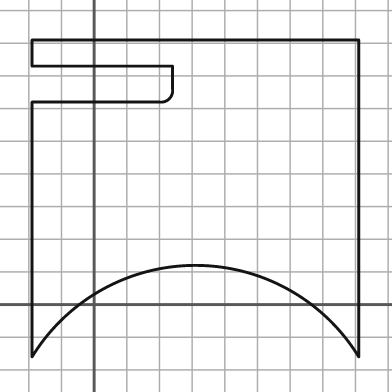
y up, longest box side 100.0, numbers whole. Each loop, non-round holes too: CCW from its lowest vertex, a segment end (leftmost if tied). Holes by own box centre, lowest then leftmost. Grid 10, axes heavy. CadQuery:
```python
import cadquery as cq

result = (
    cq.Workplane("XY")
    .moveTo(-19.0, -16.0)
    .threePointArc((31.0, 12.0), (81.0, -16.0))
    .lineTo(81.0, 81.0)
    .lineTo(-19.0, 81.0)
    .lineTo(-19.0, 73.0)
    .lineTo(24.0, 73.0)
    .lineTo(24.0, 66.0)
    .threePointArc((23.0, 63.0), (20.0, 62.0))
    .lineTo(-19.0, 62.0)
    .close()
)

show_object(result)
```